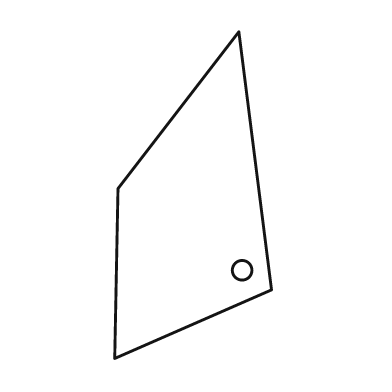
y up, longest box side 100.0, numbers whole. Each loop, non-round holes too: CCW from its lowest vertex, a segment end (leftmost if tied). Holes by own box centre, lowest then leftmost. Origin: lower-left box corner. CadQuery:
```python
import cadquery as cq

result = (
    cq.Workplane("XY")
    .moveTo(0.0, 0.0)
    .lineTo(48.0, 21.0)
    .lineTo(38.0, 100.0)
    .lineTo(1.0, 52.0)
    .close()
    .moveTo(39.0, 27.0)
    .circle(3.0)
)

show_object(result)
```